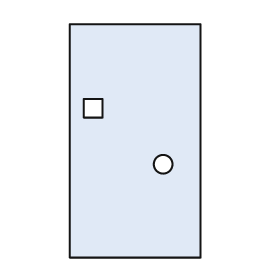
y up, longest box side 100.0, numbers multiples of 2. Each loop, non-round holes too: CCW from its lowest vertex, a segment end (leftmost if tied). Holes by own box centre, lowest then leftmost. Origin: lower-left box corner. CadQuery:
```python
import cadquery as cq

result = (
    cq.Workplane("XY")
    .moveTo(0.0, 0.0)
    .lineTo(56.0, 0.0)
    .lineTo(56.0, 100.0)
    .lineTo(0.0, 100.0)
    .close()
    .moveTo(40.0, 40.0)
    .circle(4.0)
    .moveTo(6.0, 60.0)
    .lineTo(14.0, 60.0)
    .lineTo(14.0, 68.0)
    .lineTo(6.0, 68.0)
    .close()
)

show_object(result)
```